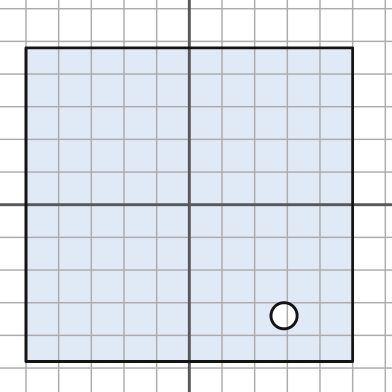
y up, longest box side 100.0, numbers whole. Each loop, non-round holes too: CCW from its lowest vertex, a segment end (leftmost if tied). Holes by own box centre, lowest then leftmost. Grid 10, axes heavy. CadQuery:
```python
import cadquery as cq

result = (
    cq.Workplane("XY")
    .moveTo(-50.0, -48.0)
    .lineTo(50.0, -48.0)
    .lineTo(50.0, 48.0)
    .lineTo(-50.0, 48.0)
    .close()
    .moveTo(29.0, -34.0)
    .circle(4.0)
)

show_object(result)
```